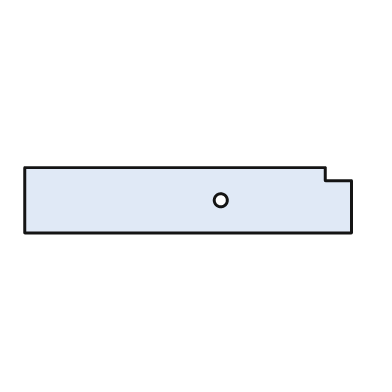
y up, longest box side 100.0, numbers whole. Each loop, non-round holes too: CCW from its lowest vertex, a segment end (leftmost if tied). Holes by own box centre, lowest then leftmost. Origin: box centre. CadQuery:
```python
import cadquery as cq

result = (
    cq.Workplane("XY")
    .moveTo(-50.0, -10.0)
    .lineTo(50.0, -10.0)
    .lineTo(50.0, 6.0)
    .lineTo(42.0, 6.0)
    .lineTo(42.0, 10.0)
    .lineTo(-50.0, 10.0)
    .close()
    .moveTo(10.0, 0.0)
    .circle(2.0)
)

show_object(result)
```